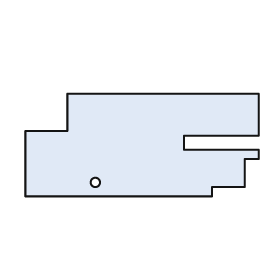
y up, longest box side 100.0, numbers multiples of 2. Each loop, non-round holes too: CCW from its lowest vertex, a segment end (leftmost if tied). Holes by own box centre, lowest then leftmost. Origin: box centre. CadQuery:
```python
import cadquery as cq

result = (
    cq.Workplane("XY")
    .moveTo(-50.0, -22.0)
    .lineTo(30.0, -22.0)
    .lineTo(30.0, -18.0)
    .lineTo(44.0, -18.0)
    .lineTo(44.0, -6.0)
    .lineTo(50.0, -6.0)
    .lineTo(50.0, -2.0)
    .lineTo(18.0, -2.0)
    .lineTo(18.0, 4.0)
    .lineTo(50.0, 4.0)
    .lineTo(50.0, 22.0)
    .lineTo(-32.0, 22.0)
    .lineTo(-32.0, 6.0)
    .lineTo(-50.0, 6.0)
    .close()
    .moveTo(-20.0, -16.0)
    .circle(2.0)
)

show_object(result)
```